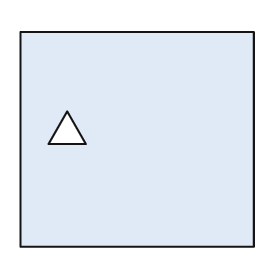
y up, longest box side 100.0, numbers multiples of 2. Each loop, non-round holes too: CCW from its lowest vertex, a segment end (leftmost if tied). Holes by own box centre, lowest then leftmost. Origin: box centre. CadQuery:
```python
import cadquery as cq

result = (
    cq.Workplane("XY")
    .moveTo(-50.0, -46.0)
    .lineTo(50.0, -46.0)
    .lineTo(50.0, 46.0)
    .lineTo(-50.0, 46.0)
    .close()
    .moveTo(-38.0, -2.0)
    .lineTo(-22.0, -2.0)
    .lineTo(-30.0, 12.0)
    .close()
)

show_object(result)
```